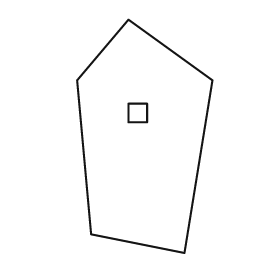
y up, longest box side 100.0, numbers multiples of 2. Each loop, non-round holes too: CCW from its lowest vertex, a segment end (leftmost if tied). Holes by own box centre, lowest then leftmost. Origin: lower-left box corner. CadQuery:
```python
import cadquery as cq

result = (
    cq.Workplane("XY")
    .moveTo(46.0, 0.0)
    .lineTo(58.0, 74.0)
    .lineTo(22.0, 100.0)
    .lineTo(0.0, 74.0)
    .lineTo(6.0, 8.0)
    .close()
    .moveTo(22.0, 56.0)
    .lineTo(30.0, 56.0)
    .lineTo(30.0, 64.0)
    .lineTo(22.0, 64.0)
    .close()
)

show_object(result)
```